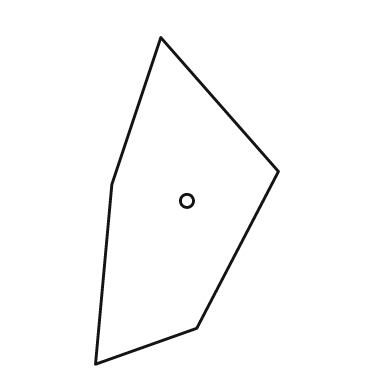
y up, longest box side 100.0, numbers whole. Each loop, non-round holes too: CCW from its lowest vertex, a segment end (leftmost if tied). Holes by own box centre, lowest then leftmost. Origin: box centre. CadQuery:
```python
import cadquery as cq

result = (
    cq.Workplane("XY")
    .moveTo(-28.0, -50.0)
    .lineTo(3.0, -39.0)
    .lineTo(28.0, 9.0)
    .lineTo(-8.0, 50.0)
    .lineTo(-23.0, 5.0)
    .close()
    .moveTo(0.0, 0.0)
    .circle(2.0)
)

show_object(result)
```